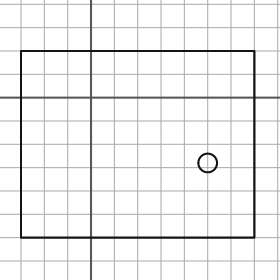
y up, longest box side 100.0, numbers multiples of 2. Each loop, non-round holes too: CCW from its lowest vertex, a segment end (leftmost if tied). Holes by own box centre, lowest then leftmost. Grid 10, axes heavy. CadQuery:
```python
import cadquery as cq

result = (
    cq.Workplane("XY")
    .moveTo(-30.0, -60.0)
    .lineTo(70.0, -60.0)
    .lineTo(70.0, 20.0)
    .lineTo(-30.0, 20.0)
    .close()
    .moveTo(50.0, -28.0)
    .circle(4.0)
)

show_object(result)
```